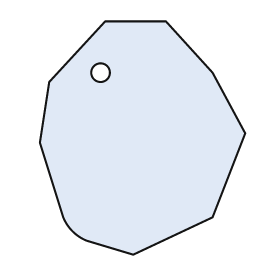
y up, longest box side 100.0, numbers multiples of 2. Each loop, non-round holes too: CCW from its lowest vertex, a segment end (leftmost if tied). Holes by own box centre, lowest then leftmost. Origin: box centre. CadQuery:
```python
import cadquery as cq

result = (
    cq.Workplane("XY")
    .moveTo(-4.0, -50.0)
    .lineTo(30.0, -34.0)
    .lineTo(44.0, 2.0)
    .lineTo(30.0, 28.0)
    .lineTo(10.0, 50.0)
    .lineTo(-16.0, 50.0)
    .lineTo(-40.0, 24.0)
    .lineTo(-44.0, -2.0)
    .lineTo(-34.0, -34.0)
    .threePointArc((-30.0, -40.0), (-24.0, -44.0))
    .close()
    .moveTo(-18.0, 28.0)
    .circle(4.0)
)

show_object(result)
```